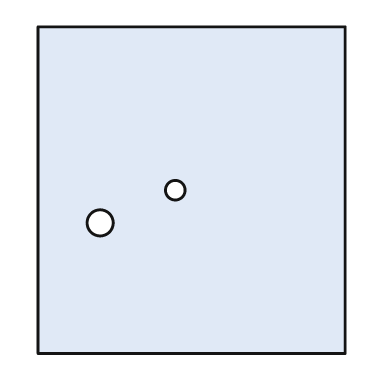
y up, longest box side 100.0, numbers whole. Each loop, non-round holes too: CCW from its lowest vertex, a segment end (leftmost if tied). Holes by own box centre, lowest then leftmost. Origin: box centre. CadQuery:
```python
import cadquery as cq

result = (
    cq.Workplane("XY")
    .moveTo(-47.0, -50.0)
    .lineTo(47.0, -50.0)
    .lineTo(47.0, 50.0)
    .lineTo(-47.0, 50.0)
    .close()
    .moveTo(-28.0, -10.0)
    .circle(4.0)
    .moveTo(-5.0, 0.0)
    .circle(3.0)
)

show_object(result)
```